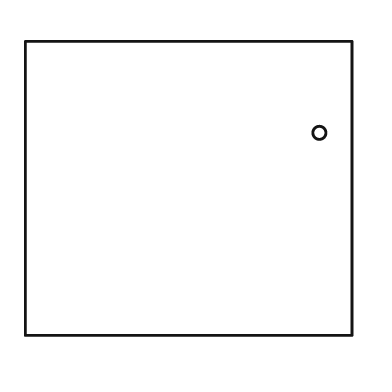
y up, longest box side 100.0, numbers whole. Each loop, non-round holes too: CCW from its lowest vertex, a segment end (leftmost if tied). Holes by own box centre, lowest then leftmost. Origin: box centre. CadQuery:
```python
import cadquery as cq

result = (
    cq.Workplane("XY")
    .moveTo(-50.0, -45.0)
    .lineTo(50.0, -45.0)
    .lineTo(50.0, 45.0)
    .lineTo(-50.0, 45.0)
    .close()
    .moveTo(40.0, 17.0)
    .circle(2.0)
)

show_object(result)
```